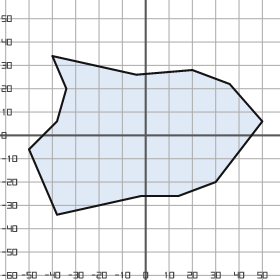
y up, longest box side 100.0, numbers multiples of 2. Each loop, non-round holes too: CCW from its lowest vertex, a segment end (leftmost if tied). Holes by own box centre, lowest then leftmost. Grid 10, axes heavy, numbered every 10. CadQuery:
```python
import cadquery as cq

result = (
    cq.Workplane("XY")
    .moveTo(-38.0, -34.0)
    .lineTo(-2.0, -26.0)
    .lineTo(14.0, -26.0)
    .lineTo(30.0, -20.0)
    .lineTo(50.0, 6.0)
    .lineTo(36.0, 22.0)
    .lineTo(20.0, 28.0)
    .lineTo(-4.0, 26.0)
    .lineTo(-40.0, 34.0)
    .lineTo(-34.0, 20.0)
    .lineTo(-38.0, 6.0)
    .lineTo(-50.0, -6.0)
    .close()
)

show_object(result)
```